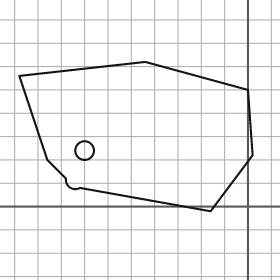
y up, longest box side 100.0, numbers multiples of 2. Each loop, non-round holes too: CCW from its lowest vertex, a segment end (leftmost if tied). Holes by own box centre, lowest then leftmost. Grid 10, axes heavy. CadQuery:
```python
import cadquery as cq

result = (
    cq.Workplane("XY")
    .moveTo(-16.0, -2.0)
    .lineTo(2.0, 22.0)
    .lineTo(0.0, 50.0)
    .lineTo(-44.0, 62.0)
    .lineTo(-98.0, 56.0)
    .lineTo(-86.0, 20.0)
    .lineTo(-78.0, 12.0)
    .threePointArc((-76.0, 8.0), (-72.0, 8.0))
    .close()
    .moveTo(-70.0, 24.0)
    .circle(4.0)
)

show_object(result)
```